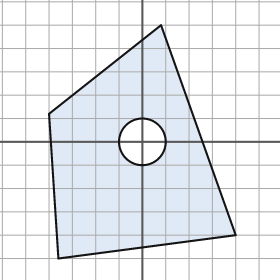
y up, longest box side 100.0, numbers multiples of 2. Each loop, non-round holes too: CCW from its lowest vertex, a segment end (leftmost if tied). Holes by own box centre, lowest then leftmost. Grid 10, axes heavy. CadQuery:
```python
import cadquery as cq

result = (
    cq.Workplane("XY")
    .moveTo(-36.0, -50.0)
    .lineTo(40.0, -40.0)
    .lineTo(8.0, 50.0)
    .lineTo(-40.0, 12.0)
    .close()
    .moveTo(0.0, 0.0)
    .circle(10.0)
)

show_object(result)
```